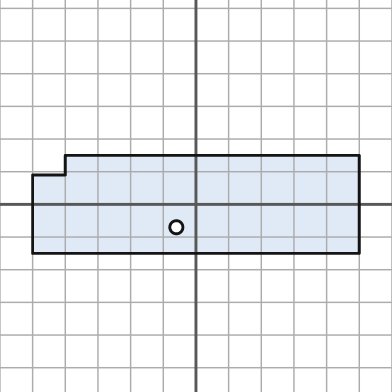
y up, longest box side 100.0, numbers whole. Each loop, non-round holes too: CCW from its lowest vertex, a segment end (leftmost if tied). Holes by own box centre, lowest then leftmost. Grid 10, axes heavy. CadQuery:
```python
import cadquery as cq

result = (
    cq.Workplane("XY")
    .moveTo(-50.0, -15.0)
    .lineTo(50.0, -15.0)
    .lineTo(50.0, 15.0)
    .lineTo(-40.0, 15.0)
    .lineTo(-40.0, 9.0)
    .lineTo(-50.0, 9.0)
    .close()
    .moveTo(-6.0, -7.0)
    .circle(2.0)
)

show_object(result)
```